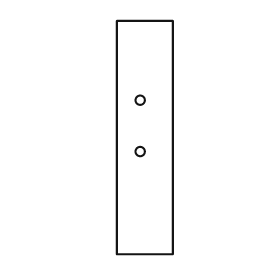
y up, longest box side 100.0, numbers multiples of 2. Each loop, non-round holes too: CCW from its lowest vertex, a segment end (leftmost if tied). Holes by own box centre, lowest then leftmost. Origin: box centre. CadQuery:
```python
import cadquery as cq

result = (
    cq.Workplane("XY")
    .moveTo(-12.0, -50.0)
    .lineTo(12.0, -50.0)
    .lineTo(12.0, 50.0)
    .lineTo(-12.0, 50.0)
    .close()
    .moveTo(-2.0, -6.0)
    .circle(2.0)
    .moveTo(-2.0, 16.0)
    .circle(2.0)
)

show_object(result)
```